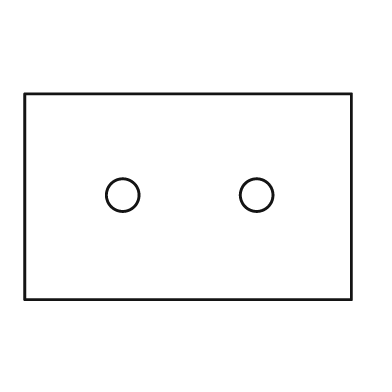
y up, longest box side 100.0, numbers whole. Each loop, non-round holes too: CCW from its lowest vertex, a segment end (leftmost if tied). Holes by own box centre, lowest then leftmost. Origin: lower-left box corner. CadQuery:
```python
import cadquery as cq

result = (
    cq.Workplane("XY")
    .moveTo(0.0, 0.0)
    .lineTo(100.0, 0.0)
    .lineTo(100.0, 63.0)
    .lineTo(0.0, 63.0)
    .close()
    .moveTo(30.0, 32.0)
    .circle(5.0)
    .moveTo(71.0, 32.0)
    .circle(5.0)
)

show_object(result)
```